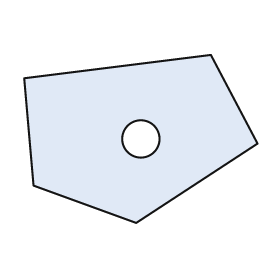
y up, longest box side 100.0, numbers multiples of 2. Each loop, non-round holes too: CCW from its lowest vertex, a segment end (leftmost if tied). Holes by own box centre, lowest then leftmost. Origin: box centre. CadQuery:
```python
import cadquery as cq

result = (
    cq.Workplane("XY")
    .moveTo(-2.0, -36.0)
    .lineTo(50.0, -2.0)
    .lineTo(30.0, 36.0)
    .lineTo(-50.0, 26.0)
    .lineTo(-46.0, -20.0)
    .close()
    .moveTo(0.0, 0.0)
    .circle(8.0)
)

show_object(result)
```